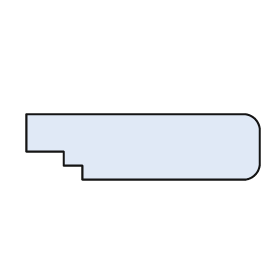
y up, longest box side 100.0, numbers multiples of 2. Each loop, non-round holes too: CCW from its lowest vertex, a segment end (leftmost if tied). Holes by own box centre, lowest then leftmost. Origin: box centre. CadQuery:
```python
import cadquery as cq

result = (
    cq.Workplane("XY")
    .moveTo(-26.0, -14.0)
    .lineTo(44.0, -14.0)
    .threePointArc((48.0, -12.0), (50.0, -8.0))
    .lineTo(50.0, 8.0)
    .threePointArc((48.0, 12.0), (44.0, 14.0))
    .lineTo(-50.0, 14.0)
    .lineTo(-50.0, -2.0)
    .lineTo(-34.0, -2.0)
    .lineTo(-34.0, -8.0)
    .lineTo(-26.0, -8.0)
    .close()
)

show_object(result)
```